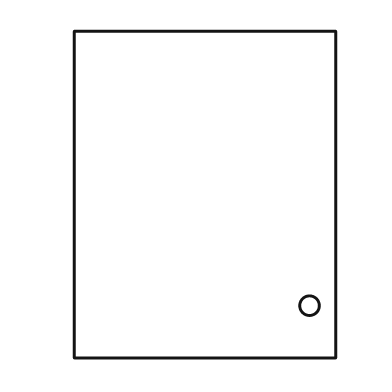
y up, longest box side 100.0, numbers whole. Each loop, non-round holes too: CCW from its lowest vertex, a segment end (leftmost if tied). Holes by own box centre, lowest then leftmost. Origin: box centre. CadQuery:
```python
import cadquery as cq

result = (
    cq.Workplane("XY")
    .moveTo(-40.0, -50.0)
    .lineTo(40.0, -50.0)
    .lineTo(40.0, 50.0)
    .lineTo(-40.0, 50.0)
    .close()
    .moveTo(32.0, -34.0)
    .circle(3.0)
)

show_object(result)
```